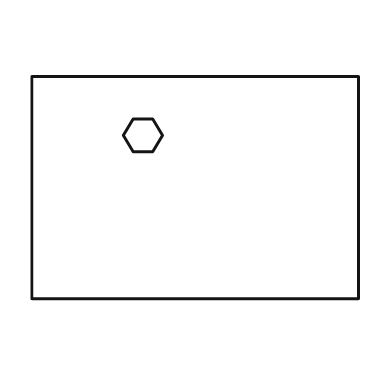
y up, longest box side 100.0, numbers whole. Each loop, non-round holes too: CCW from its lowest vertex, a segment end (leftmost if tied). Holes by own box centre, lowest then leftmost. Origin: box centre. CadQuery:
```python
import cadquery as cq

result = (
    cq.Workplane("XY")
    .moveTo(-50.0, -34.0)
    .lineTo(50.0, -34.0)
    .lineTo(50.0, 34.0)
    .lineTo(-50.0, 34.0)
    .close()
    .moveTo(-19.0, 11.0)
    .lineTo(-13.0, 11.0)
    .lineTo(-10.0, 16.0)
    .lineTo(-13.0, 21.0)
    .lineTo(-19.0, 21.0)
    .lineTo(-22.0, 16.0)
    .close()
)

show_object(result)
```